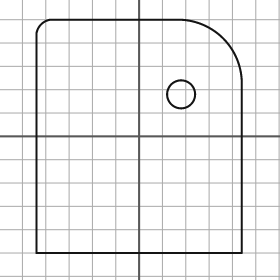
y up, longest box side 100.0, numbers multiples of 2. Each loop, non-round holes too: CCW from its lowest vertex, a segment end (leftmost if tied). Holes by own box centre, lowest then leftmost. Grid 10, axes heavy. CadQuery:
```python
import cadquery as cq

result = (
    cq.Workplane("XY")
    .moveTo(-44.0, -50.0)
    .lineTo(44.0, -50.0)
    .lineTo(44.0, 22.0)
    .threePointArc((36.0, 42.0), (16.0, 50.0))
    .lineTo(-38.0, 50.0)
    .threePointArc((-42.0, 48.0), (-44.0, 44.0))
    .close()
    .moveTo(18.0, 18.0)
    .circle(6.0)
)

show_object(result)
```